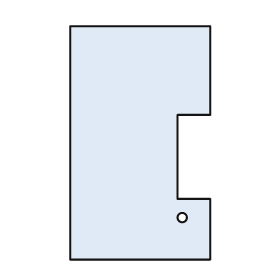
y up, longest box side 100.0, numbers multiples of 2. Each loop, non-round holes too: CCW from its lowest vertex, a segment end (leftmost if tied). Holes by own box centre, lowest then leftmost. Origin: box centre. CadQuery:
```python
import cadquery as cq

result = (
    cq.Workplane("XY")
    .moveTo(-30.0, -50.0)
    .lineTo(30.0, -50.0)
    .lineTo(30.0, -24.0)
    .lineTo(16.0, -24.0)
    .lineTo(16.0, 12.0)
    .lineTo(30.0, 12.0)
    .lineTo(30.0, 50.0)
    .lineTo(-30.0, 50.0)
    .close()
    .moveTo(18.0, -32.0)
    .circle(2.0)
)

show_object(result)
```